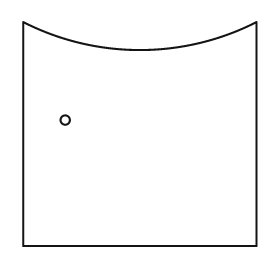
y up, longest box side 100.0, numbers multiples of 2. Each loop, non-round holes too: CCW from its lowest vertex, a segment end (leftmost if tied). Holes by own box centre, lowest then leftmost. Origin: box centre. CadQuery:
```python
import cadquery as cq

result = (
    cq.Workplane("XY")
    .moveTo(-50.0, -48.0)
    .lineTo(50.0, -48.0)
    .lineTo(50.0, 48.0)
    .threePointArc((0.0, 36.0), (-50.0, 48.0))
    .close()
    .moveTo(-32.0, 6.0)
    .circle(2.0)
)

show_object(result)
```